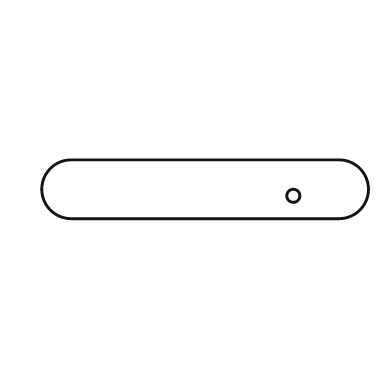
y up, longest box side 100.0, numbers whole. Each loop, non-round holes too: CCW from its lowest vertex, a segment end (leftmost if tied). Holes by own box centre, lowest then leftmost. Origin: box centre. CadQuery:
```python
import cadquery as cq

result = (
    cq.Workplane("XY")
    .moveTo(-41.0, -9.0)
    .lineTo(41.0, -9.0)
    .threePointArc((50.0, 0.0), (41.0, 9.0))
    .lineTo(-41.0, 9.0)
    .threePointArc((-50.0, 0.0), (-41.0, -9.0))
    .close()
    .moveTo(27.0, -2.0)
    .circle(2.0)
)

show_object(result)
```